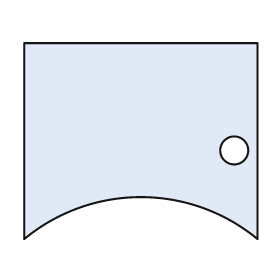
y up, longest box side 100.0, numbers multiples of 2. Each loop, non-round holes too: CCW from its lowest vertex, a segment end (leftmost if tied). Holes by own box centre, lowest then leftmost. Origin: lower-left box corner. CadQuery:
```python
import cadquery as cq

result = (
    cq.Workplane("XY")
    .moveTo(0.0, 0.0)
    .threePointArc((50.0, 18.0), (100.0, 0.0))
    .lineTo(100.0, 84.0)
    .lineTo(0.0, 84.0)
    .close()
    .moveTo(90.0, 38.0)
    .circle(6.0)
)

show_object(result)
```